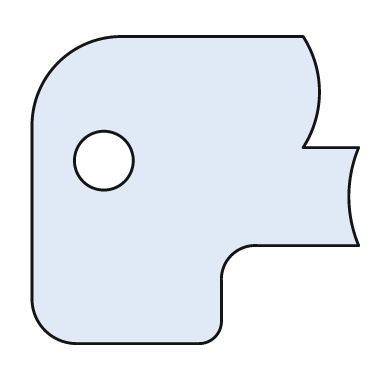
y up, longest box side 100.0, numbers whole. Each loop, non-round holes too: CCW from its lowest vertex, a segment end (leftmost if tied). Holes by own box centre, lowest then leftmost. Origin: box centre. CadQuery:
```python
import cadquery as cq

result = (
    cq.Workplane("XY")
    .moveTo(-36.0, -47.0)
    .lineTo(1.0, -47.0)
    .threePointArc((6.0, -45.0), (8.0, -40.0))
    .lineTo(8.0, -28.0)
    .threePointArc((11.0, -20.0), (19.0, -17.0))
    .lineTo(50.0, -17.0)
    .threePointArc((47.0, -2.0), (50.0, 13.0))
    .lineTo(33.0, 13.0)
    .threePointArc((38.0, 30.0), (33.0, 47.0))
    .lineTo(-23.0, 47.0)
    .threePointArc((-42.0, 39.0), (-50.0, 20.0))
    .lineTo(-50.0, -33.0)
    .threePointArc((-46.0, -43.0), (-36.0, -47.0))
    .close()
    .moveTo(-28.0, 9.0)
    .circle(9.0)
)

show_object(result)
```